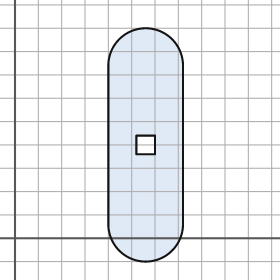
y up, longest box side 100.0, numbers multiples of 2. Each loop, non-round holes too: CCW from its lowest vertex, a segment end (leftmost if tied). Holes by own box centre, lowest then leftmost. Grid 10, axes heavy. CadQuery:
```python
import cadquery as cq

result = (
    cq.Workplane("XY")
    .moveTo(40.0, 6.0)
    .threePointArc((56.0, -10.0), (72.0, 6.0))
    .lineTo(72.0, 74.0)
    .threePointArc((56.0, 90.0), (40.0, 74.0))
    .close()
    .moveTo(52.0, 36.0)
    .lineTo(60.0, 36.0)
    .lineTo(60.0, 44.0)
    .lineTo(52.0, 44.0)
    .close()
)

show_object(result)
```